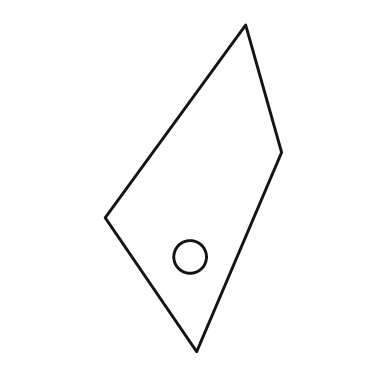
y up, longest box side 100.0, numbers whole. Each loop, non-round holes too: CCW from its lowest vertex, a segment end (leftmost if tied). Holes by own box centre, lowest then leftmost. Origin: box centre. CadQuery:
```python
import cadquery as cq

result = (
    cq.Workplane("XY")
    .moveTo(1.0, -50.0)
    .lineTo(27.0, 11.0)
    .lineTo(16.0, 50.0)
    .lineTo(-27.0, -9.0)
    .close()
    .moveTo(-1.0, -21.0)
    .circle(5.0)
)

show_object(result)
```